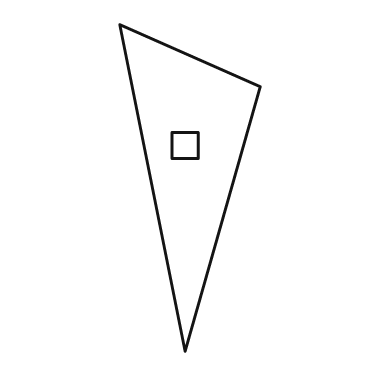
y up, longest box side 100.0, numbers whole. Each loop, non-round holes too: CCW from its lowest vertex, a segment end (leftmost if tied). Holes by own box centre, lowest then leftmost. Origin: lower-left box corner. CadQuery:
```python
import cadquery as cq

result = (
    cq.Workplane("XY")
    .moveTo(20.0, 0.0)
    .lineTo(43.0, 81.0)
    .lineTo(0.0, 100.0)
    .close()
    .moveTo(16.0, 59.0)
    .lineTo(24.0, 59.0)
    .lineTo(24.0, 67.0)
    .lineTo(16.0, 67.0)
    .close()
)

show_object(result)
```